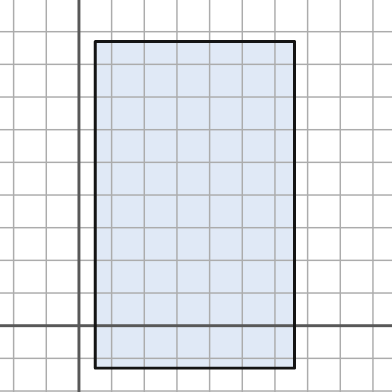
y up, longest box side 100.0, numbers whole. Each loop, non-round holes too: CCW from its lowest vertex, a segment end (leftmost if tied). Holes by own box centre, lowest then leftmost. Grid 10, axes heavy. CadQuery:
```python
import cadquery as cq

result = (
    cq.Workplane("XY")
    .moveTo(5.0, -13.0)
    .lineTo(66.0, -13.0)
    .lineTo(66.0, 87.0)
    .lineTo(5.0, 87.0)
    .close()
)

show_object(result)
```